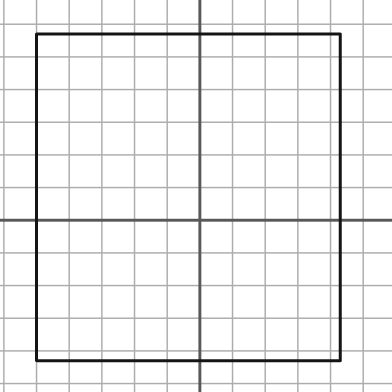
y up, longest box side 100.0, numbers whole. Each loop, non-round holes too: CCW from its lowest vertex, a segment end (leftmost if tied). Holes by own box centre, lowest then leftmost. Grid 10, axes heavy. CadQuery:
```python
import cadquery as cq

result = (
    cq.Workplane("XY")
    .moveTo(-50.0, -43.0)
    .lineTo(43.0, -43.0)
    .lineTo(43.0, 57.0)
    .lineTo(-50.0, 57.0)
    .close()
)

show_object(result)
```